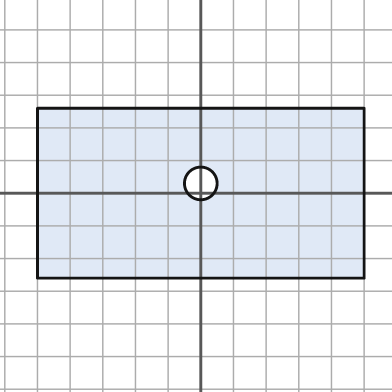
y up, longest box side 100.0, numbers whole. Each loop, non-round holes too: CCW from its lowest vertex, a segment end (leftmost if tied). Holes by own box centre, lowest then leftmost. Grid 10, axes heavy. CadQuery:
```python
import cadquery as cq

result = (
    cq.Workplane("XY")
    .moveTo(-50.0, -26.0)
    .lineTo(50.0, -26.0)
    .lineTo(50.0, 26.0)
    .lineTo(-50.0, 26.0)
    .close()
    .moveTo(0.0, 3.0)
    .circle(5.0)
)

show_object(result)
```